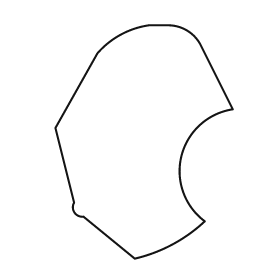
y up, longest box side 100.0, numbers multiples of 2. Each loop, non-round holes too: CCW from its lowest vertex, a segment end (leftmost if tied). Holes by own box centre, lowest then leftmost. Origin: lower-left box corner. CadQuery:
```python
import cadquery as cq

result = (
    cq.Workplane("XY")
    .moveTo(34.0, 0.0)
    .threePointArc((50.0, 6.0), (64.0, 16.0))
    .threePointArc((54.0, 44.0), (76.0, 64.0))
    .lineTo(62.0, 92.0)
    .threePointArc((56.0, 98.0), (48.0, 100.0))
    .lineTo(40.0, 100.0)
    .threePointArc((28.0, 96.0), (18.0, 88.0))
    .lineTo(0.0, 56.0)
    .lineTo(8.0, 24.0)
    .threePointArc((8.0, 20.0), (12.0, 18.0))
    .close()
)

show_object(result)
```